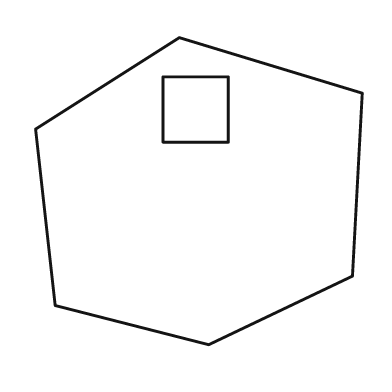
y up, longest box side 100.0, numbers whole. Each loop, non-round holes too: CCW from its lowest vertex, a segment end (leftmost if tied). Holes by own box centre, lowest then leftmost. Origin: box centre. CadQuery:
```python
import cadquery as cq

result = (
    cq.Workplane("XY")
    .moveTo(3.0, -47.0)
    .lineTo(47.0, -26.0)
    .lineTo(50.0, 30.0)
    .lineTo(-6.0, 47.0)
    .lineTo(-50.0, 19.0)
    .lineTo(-44.0, -35.0)
    .close()
    .moveTo(-11.0, 15.0)
    .lineTo(9.0, 15.0)
    .lineTo(9.0, 35.0)
    .lineTo(-11.0, 35.0)
    .close()
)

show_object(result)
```